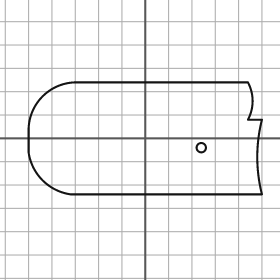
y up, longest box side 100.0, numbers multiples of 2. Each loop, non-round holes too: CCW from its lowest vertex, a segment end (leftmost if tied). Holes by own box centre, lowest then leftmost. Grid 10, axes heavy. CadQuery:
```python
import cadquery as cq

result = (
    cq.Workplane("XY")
    .moveTo(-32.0, -24.0)
    .lineTo(50.0, -24.0)
    .threePointArc((48.0, -8.0), (50.0, 8.0))
    .lineTo(44.0, 8.0)
    .threePointArc((46.0, 16.0), (44.0, 24.0))
    .lineTo(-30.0, 24.0)
    .threePointArc((-44.0, 18.0), (-50.0, 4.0))
    .lineTo(-50.0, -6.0)
    .threePointArc((-44.0, -18.0), (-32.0, -24.0))
    .close()
    .moveTo(24.0, -4.0)
    .circle(2.0)
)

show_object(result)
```